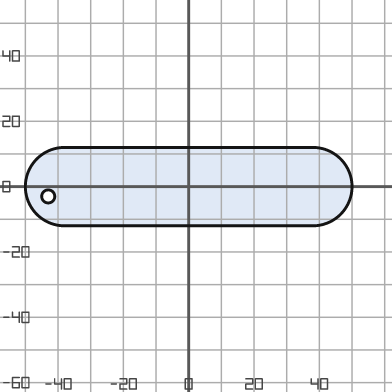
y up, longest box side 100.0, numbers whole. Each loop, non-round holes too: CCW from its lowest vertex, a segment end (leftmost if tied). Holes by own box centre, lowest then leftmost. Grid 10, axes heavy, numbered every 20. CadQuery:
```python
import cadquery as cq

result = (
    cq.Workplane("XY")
    .moveTo(-38.0, -12.0)
    .lineTo(38.0, -12.0)
    .threePointArc((50.0, 0.0), (38.0, 12.0))
    .lineTo(-38.0, 12.0)
    .threePointArc((-50.0, 0.0), (-38.0, -12.0))
    .close()
    .moveTo(-43.0, -3.0)
    .circle(2.0)
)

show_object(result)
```